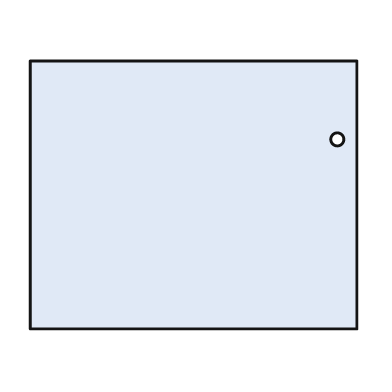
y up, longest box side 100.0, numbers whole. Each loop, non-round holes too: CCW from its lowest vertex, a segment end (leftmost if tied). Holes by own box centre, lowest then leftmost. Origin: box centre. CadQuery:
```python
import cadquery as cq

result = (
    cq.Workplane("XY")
    .moveTo(-50.0, -41.0)
    .lineTo(50.0, -41.0)
    .lineTo(50.0, 41.0)
    .lineTo(-50.0, 41.0)
    .close()
    .moveTo(44.0, 17.0)
    .circle(2.0)
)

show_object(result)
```